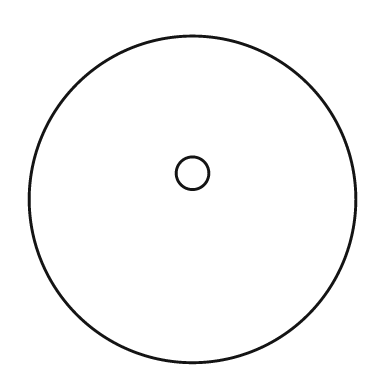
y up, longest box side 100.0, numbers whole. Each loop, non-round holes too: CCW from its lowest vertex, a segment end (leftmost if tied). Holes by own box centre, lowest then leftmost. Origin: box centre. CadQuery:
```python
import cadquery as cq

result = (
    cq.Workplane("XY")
    .moveTo(0.0, 0.0)
    .circle(50.0)
    .moveTo(0.0, 8.0)
    .circle(5.0)
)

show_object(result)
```